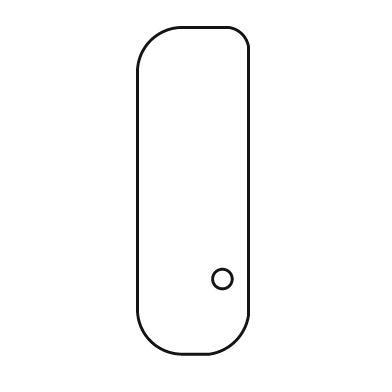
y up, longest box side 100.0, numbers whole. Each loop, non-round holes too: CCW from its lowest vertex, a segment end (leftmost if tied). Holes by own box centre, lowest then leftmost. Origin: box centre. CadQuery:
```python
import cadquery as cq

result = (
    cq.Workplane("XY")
    .moveTo(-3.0, -50.0)
    .lineTo(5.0, -50.0)
    .threePointArc((13.0, -46.0), (17.0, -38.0))
    .lineTo(17.0, 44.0)
    .threePointArc((15.0, 48.0), (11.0, 50.0))
    .lineTo(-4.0, 50.0)
    .threePointArc((-13.0, 46.0), (-17.0, 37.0))
    .lineTo(-17.0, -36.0)
    .threePointArc((-13.0, -46.0), (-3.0, -50.0))
    .close()
    .moveTo(9.0, -27.0)
    .circle(3.0)
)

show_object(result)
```